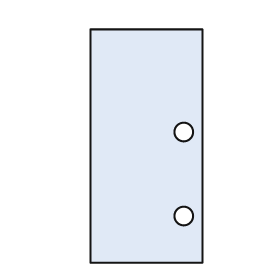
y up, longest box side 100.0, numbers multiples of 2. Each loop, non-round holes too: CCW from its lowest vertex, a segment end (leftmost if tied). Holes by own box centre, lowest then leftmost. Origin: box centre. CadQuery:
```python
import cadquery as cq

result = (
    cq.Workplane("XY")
    .moveTo(-24.0, -50.0)
    .lineTo(24.0, -50.0)
    .lineTo(24.0, 50.0)
    .lineTo(-24.0, 50.0)
    .close()
    .moveTo(16.0, -30.0)
    .circle(4.0)
    .moveTo(16.0, 6.0)
    .circle(4.0)
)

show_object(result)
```